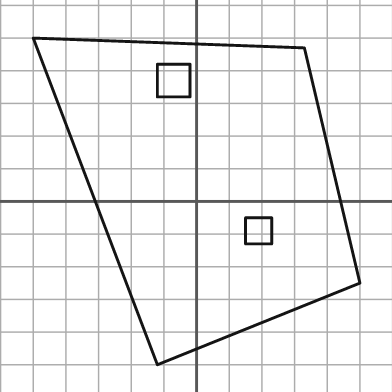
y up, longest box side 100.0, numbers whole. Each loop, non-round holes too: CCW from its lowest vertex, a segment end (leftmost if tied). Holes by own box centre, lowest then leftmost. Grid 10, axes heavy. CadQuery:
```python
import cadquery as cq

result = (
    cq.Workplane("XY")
    .moveTo(-12.0, -50.0)
    .lineTo(50.0, -25.0)
    .lineTo(33.0, 47.0)
    .lineTo(-50.0, 50.0)
    .close()
    .moveTo(15.0, -13.0)
    .lineTo(23.0, -13.0)
    .lineTo(23.0, -5.0)
    .lineTo(15.0, -5.0)
    .close()
    .moveTo(-12.0, 32.0)
    .lineTo(-2.0, 32.0)
    .lineTo(-2.0, 42.0)
    .lineTo(-12.0, 42.0)
    .close()
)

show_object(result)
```